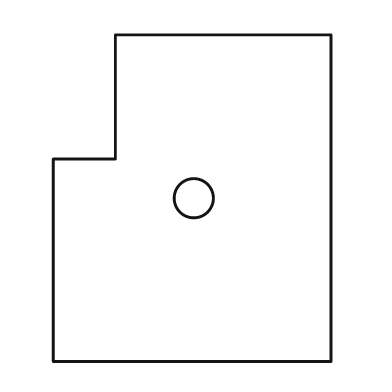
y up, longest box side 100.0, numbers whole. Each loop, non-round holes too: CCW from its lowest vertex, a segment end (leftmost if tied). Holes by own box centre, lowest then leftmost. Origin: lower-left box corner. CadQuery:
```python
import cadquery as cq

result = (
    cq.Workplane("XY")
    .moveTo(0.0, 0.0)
    .lineTo(85.0, 0.0)
    .lineTo(85.0, 100.0)
    .lineTo(19.0, 100.0)
    .lineTo(19.0, 62.0)
    .lineTo(0.0, 62.0)
    .close()
    .moveTo(43.0, 50.0)
    .circle(6.0)
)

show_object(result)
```